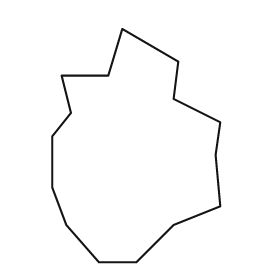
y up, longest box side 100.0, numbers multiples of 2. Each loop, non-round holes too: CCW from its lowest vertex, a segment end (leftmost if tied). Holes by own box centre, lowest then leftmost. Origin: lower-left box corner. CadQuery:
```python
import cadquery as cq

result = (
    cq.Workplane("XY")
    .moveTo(20.0, 0.0)
    .lineTo(36.0, 0.0)
    .lineTo(52.0, 16.0)
    .lineTo(72.0, 24.0)
    .lineTo(70.0, 46.0)
    .lineTo(72.0, 60.0)
    .lineTo(52.0, 70.0)
    .lineTo(54.0, 86.0)
    .lineTo(30.0, 100.0)
    .lineTo(24.0, 80.0)
    .lineTo(4.0, 80.0)
    .lineTo(8.0, 64.0)
    .lineTo(0.0, 54.0)
    .lineTo(0.0, 32.0)
    .lineTo(6.0, 16.0)
    .close()
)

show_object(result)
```